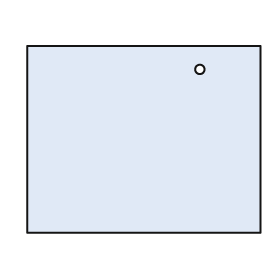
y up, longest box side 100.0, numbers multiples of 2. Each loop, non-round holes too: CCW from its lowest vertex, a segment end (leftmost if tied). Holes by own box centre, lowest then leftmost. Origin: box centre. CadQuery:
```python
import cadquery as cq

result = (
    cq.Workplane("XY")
    .moveTo(-50.0, -40.0)
    .lineTo(50.0, -40.0)
    .lineTo(50.0, 40.0)
    .lineTo(-50.0, 40.0)
    .close()
    .moveTo(24.0, 30.0)
    .circle(2.0)
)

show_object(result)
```